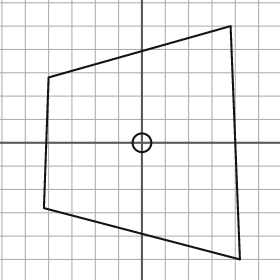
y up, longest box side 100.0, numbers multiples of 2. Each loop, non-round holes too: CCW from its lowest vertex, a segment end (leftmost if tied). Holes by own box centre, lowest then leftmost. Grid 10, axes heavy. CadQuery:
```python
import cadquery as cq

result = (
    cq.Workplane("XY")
    .moveTo(42.0, -50.0)
    .lineTo(38.0, 50.0)
    .lineTo(-40.0, 28.0)
    .lineTo(-42.0, -28.0)
    .close()
    .moveTo(0.0, 0.0)
    .circle(4.0)
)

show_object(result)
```